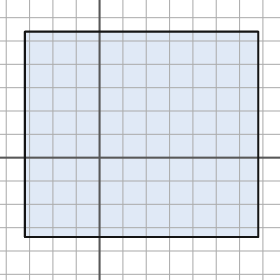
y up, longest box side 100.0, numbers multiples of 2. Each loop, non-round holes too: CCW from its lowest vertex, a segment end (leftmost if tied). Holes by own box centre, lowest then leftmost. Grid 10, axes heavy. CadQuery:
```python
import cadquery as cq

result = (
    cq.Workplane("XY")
    .moveTo(-32.0, -34.0)
    .lineTo(68.0, -34.0)
    .lineTo(68.0, 54.0)
    .lineTo(-32.0, 54.0)
    .close()
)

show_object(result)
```